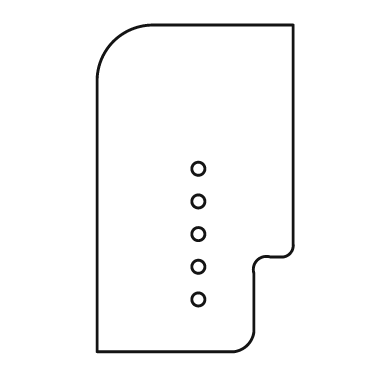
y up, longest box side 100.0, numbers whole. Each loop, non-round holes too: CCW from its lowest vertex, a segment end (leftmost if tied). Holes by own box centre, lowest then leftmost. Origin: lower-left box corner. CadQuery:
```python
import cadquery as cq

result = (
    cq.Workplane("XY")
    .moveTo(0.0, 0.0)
    .lineTo(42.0, 0.0)
    .threePointArc((46.0, 2.0), (48.0, 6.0))
    .lineTo(48.0, 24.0)
    .threePointArc((49.0, 28.0), (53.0, 29.0))
    .lineTo(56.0, 29.0)
    .threePointArc((59.0, 30.0), (60.0, 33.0))
    .lineTo(60.0, 100.0)
    .lineTo(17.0, 100.0)
    .threePointArc((5.0, 95.0), (0.0, 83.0))
    .close()
    .moveTo(31.0, 16.0)
    .circle(2.0)
    .moveTo(31.0, 26.0)
    .circle(2.0)
    .moveTo(31.0, 36.0)
    .circle(2.0)
    .moveTo(31.0, 46.0)
    .circle(2.0)
    .moveTo(31.0, 56.0)
    .circle(2.0)
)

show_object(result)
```